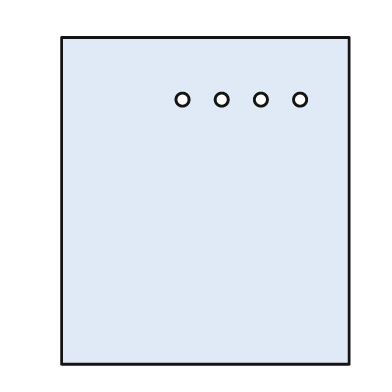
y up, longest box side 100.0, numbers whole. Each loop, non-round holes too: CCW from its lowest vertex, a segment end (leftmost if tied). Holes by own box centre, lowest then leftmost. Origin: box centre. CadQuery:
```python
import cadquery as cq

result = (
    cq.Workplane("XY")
    .moveTo(-44.0, -50.0)
    .lineTo(44.0, -50.0)
    .lineTo(44.0, 50.0)
    .lineTo(-44.0, 50.0)
    .close()
    .moveTo(-7.0, 31.0)
    .circle(2.0)
    .moveTo(5.0, 31.0)
    .circle(2.0)
    .moveTo(17.0, 31.0)
    .circle(2.0)
    .moveTo(29.0, 31.0)
    .circle(2.0)
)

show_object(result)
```